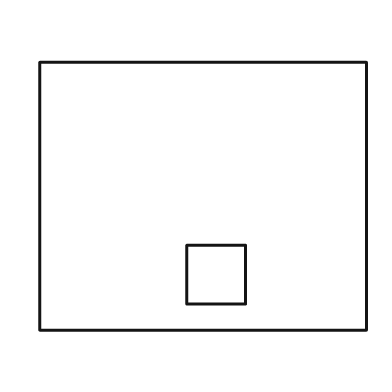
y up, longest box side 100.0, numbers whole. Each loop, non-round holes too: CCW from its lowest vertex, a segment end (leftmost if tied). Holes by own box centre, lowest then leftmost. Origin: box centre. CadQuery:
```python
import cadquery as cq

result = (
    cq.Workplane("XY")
    .moveTo(-50.0, -41.0)
    .lineTo(50.0, -41.0)
    .lineTo(50.0, 41.0)
    .lineTo(-50.0, 41.0)
    .close()
    .moveTo(-5.0, -33.0)
    .lineTo(13.0, -33.0)
    .lineTo(13.0, -15.0)
    .lineTo(-5.0, -15.0)
    .close()
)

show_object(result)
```